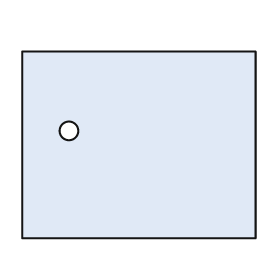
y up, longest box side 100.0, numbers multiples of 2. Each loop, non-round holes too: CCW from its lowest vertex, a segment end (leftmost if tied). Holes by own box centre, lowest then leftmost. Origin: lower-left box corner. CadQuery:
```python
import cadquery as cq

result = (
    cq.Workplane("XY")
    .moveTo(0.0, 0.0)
    .lineTo(100.0, 0.0)
    .lineTo(100.0, 80.0)
    .lineTo(0.0, 80.0)
    .close()
    .moveTo(20.0, 46.0)
    .circle(4.0)
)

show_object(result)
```